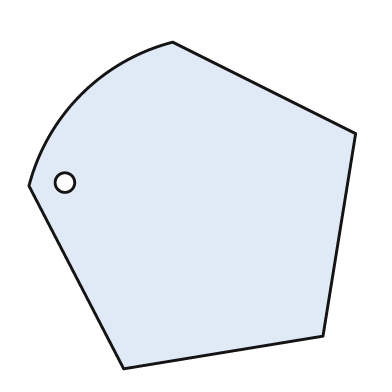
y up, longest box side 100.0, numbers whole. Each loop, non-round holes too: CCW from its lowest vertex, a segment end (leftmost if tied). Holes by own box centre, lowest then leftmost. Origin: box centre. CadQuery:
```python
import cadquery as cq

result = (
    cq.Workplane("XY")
    .moveTo(-21.0, -50.0)
    .lineTo(40.0, -40.0)
    .lineTo(50.0, 22.0)
    .lineTo(-6.0, 50.0)
    .threePointArc((-34.0, 34.0), (-50.0, 6.0))
    .close()
    .moveTo(-39.0, 7.0)
    .circle(3.0)
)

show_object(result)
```